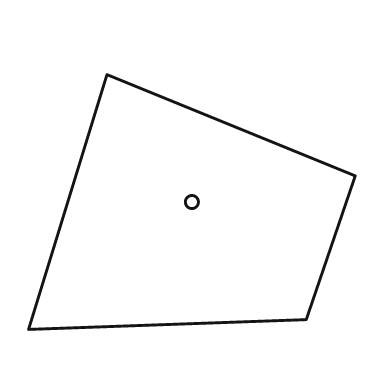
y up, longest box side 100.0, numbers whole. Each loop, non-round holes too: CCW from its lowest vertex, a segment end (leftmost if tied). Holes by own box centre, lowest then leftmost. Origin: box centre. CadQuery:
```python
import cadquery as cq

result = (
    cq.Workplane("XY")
    .moveTo(-50.0, -39.0)
    .lineTo(35.0, -36.0)
    .lineTo(50.0, 8.0)
    .lineTo(-26.0, 39.0)
    .close()
    .moveTo(0.0, 0.0)
    .circle(2.0)
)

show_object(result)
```